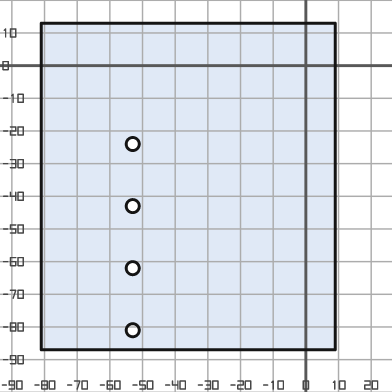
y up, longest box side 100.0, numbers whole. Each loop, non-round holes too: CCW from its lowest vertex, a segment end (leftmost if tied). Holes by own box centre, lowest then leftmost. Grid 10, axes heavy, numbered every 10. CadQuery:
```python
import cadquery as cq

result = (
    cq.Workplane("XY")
    .moveTo(-81.0, -87.0)
    .lineTo(9.0, -87.0)
    .lineTo(9.0, 13.0)
    .lineTo(-81.0, 13.0)
    .close()
    .moveTo(-53.0, -81.0)
    .circle(2.0)
    .moveTo(-53.0, -62.0)
    .circle(2.0)
    .moveTo(-53.0, -43.0)
    .circle(2.0)
    .moveTo(-53.0, -24.0)
    .circle(2.0)
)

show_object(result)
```